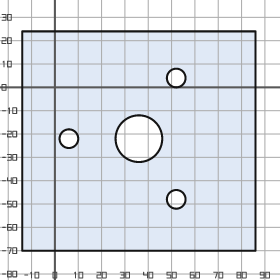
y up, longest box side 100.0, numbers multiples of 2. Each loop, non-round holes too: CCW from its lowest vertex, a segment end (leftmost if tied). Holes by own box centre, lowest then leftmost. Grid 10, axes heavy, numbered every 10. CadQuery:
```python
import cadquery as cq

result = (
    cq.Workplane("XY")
    .moveTo(-14.0, -70.0)
    .lineTo(86.0, -70.0)
    .lineTo(86.0, 24.0)
    .lineTo(-14.0, 24.0)
    .close()
    .moveTo(52.0, -48.0)
    .circle(4.0)
    .moveTo(6.0, -22.0)
    .circle(4.0)
    .moveTo(36.0, -22.0)
    .circle(10.0)
    .moveTo(52.0, 4.0)
    .circle(4.0)
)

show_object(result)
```